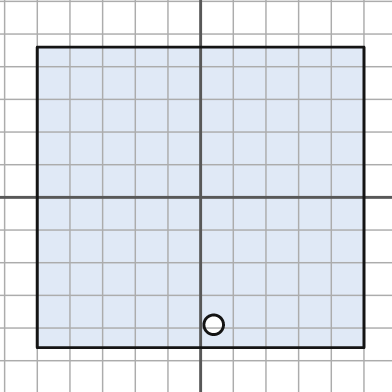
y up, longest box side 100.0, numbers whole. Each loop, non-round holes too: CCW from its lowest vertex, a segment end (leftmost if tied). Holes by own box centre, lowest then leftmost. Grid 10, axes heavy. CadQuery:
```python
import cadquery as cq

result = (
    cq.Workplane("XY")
    .moveTo(-50.0, -46.0)
    .lineTo(50.0, -46.0)
    .lineTo(50.0, 46.0)
    .lineTo(-50.0, 46.0)
    .close()
    .moveTo(4.0, -39.0)
    .circle(3.0)
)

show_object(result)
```